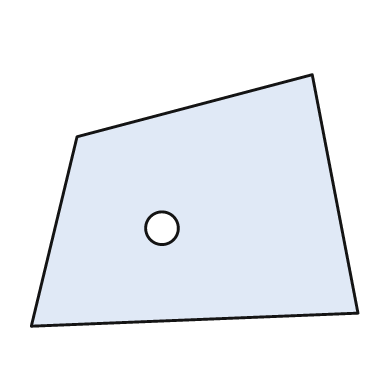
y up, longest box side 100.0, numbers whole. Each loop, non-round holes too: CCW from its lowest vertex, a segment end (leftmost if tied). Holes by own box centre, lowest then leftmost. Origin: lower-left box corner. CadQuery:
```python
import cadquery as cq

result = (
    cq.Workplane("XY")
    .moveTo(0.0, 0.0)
    .lineTo(100.0, 4.0)
    .lineTo(86.0, 77.0)
    .lineTo(14.0, 58.0)
    .close()
    .moveTo(40.0, 30.0)
    .circle(5.0)
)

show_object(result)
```